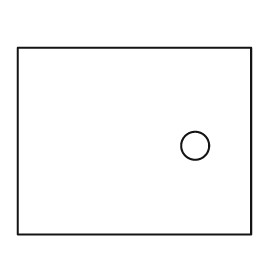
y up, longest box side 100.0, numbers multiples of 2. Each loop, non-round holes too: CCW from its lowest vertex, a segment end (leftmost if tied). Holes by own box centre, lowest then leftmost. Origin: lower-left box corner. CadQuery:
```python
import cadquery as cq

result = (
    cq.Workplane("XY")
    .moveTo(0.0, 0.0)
    .lineTo(100.0, 0.0)
    .lineTo(100.0, 80.0)
    .lineTo(0.0, 80.0)
    .close()
    .moveTo(76.0, 38.0)
    .circle(6.0)
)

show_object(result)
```